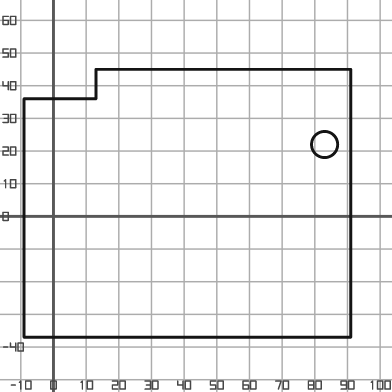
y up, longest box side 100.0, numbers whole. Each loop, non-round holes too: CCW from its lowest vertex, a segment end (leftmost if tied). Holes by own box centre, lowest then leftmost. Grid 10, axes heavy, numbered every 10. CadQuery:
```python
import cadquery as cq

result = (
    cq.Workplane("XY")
    .moveTo(-9.0, -37.0)
    .lineTo(91.0, -37.0)
    .lineTo(91.0, 45.0)
    .lineTo(13.0, 45.0)
    .lineTo(13.0, 36.0)
    .lineTo(-9.0, 36.0)
    .close()
    .moveTo(83.0, 22.0)
    .circle(4.0)
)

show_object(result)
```